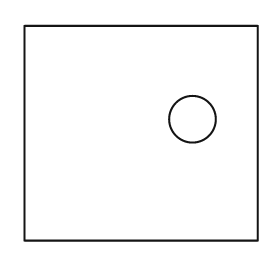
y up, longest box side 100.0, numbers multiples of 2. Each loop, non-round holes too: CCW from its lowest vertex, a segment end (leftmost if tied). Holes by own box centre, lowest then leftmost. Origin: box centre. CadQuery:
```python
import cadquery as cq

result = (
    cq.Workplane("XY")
    .moveTo(-50.0, -46.0)
    .lineTo(50.0, -46.0)
    .lineTo(50.0, 46.0)
    .lineTo(-50.0, 46.0)
    .close()
    .moveTo(22.0, 6.0)
    .circle(10.0)
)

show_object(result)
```